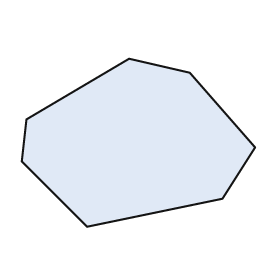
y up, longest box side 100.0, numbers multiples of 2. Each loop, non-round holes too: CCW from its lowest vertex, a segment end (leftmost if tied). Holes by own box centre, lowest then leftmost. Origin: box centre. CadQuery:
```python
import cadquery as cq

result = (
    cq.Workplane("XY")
    .moveTo(-22.0, -36.0)
    .lineTo(36.0, -24.0)
    .lineTo(50.0, -2.0)
    .lineTo(22.0, 30.0)
    .lineTo(-4.0, 36.0)
    .lineTo(-48.0, 10.0)
    .lineTo(-50.0, -8.0)
    .close()
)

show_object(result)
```